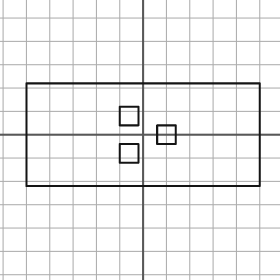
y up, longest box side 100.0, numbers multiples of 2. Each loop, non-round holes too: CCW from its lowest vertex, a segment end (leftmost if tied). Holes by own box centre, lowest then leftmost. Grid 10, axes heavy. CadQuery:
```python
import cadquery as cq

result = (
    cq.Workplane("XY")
    .moveTo(-50.0, -22.0)
    .lineTo(50.0, -22.0)
    .lineTo(50.0, 22.0)
    .lineTo(-50.0, 22.0)
    .close()
    .moveTo(-10.0, -12.0)
    .lineTo(-2.0, -12.0)
    .lineTo(-2.0, -4.0)
    .lineTo(-10.0, -4.0)
    .close()
    .moveTo(6.0, -4.0)
    .lineTo(14.0, -4.0)
    .lineTo(14.0, 4.0)
    .lineTo(6.0, 4.0)
    .close()
    .moveTo(-10.0, 4.0)
    .lineTo(-2.0, 4.0)
    .lineTo(-2.0, 12.0)
    .lineTo(-10.0, 12.0)
    .close()
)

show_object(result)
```